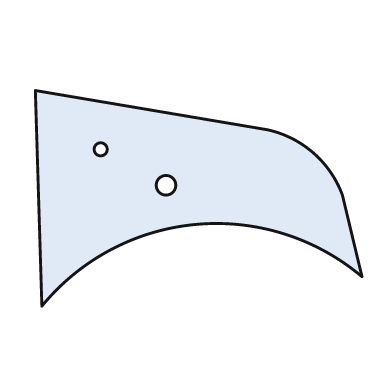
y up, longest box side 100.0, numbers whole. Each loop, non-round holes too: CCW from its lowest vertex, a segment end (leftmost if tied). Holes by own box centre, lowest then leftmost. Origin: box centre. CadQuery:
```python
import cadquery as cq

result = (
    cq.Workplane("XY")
    .moveTo(-48.0, -33.0)
    .threePointArc((-1.0, -8.0), (50.0, -24.0))
    .lineTo(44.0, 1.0)
    .threePointArc((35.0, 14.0), (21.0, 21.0))
    .lineTo(-50.0, 33.0)
    .close()
    .moveTo(-10.0, 4.0)
    .circle(3.0)
    .moveTo(-30.0, 15.0)
    .circle(2.0)
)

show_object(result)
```